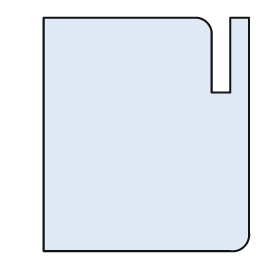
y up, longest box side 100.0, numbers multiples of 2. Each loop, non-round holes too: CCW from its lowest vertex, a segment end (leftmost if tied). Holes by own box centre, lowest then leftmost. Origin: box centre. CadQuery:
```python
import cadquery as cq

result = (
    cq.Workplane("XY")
    .moveTo(-44.0, -50.0)
    .lineTo(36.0, -50.0)
    .threePointArc((42.0, -48.0), (44.0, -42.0))
    .lineTo(44.0, 50.0)
    .lineTo(36.0, 50.0)
    .lineTo(36.0, 18.0)
    .lineTo(28.0, 18.0)
    .lineTo(28.0, 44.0)
    .threePointArc((26.0, 48.0), (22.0, 50.0))
    .lineTo(-44.0, 50.0)
    .close()
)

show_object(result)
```